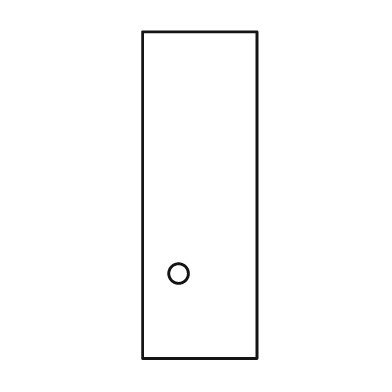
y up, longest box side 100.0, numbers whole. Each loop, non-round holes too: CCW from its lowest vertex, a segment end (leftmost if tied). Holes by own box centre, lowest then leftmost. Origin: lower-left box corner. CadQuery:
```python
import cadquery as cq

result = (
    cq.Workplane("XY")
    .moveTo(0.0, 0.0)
    .lineTo(35.0, 0.0)
    .lineTo(35.0, 100.0)
    .lineTo(0.0, 100.0)
    .close()
    .moveTo(11.0, 26.0)
    .circle(3.0)
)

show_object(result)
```